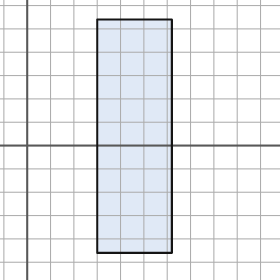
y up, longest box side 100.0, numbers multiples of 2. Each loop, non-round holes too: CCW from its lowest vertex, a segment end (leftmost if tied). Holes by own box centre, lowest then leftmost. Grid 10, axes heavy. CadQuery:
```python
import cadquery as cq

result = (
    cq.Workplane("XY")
    .moveTo(30.0, -46.0)
    .lineTo(62.0, -46.0)
    .lineTo(62.0, 54.0)
    .lineTo(30.0, 54.0)
    .close()
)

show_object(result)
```